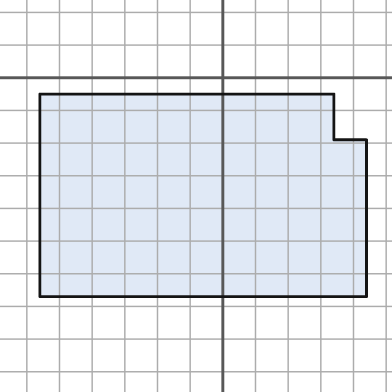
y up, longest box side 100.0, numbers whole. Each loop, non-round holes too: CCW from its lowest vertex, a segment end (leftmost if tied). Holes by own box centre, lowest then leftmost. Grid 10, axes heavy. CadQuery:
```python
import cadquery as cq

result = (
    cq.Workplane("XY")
    .moveTo(-56.0, -67.0)
    .lineTo(44.0, -67.0)
    .lineTo(44.0, -19.0)
    .lineTo(34.0, -19.0)
    .lineTo(34.0, -5.0)
    .lineTo(-56.0, -5.0)
    .close()
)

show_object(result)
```